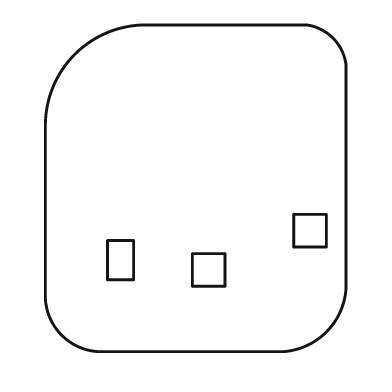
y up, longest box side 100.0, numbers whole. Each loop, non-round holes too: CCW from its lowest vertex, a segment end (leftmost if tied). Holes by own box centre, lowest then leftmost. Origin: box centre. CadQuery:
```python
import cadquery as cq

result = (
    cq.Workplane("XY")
    .moveTo(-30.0, -50.0)
    .lineTo(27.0, -50.0)
    .threePointArc((40.0, -44.0), (46.0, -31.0))
    .lineTo(46.0, 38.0)
    .threePointArc((42.0, 46.0), (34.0, 50.0))
    .lineTo(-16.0, 50.0)
    .threePointArc((-37.0, 41.0), (-46.0, 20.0))
    .lineTo(-46.0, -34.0)
    .threePointArc((-41.0, -45.0), (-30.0, -50.0))
    .close()
    .moveTo(-1.0, -30.0)
    .lineTo(9.0, -30.0)
    .lineTo(9.0, -20.0)
    .lineTo(-1.0, -20.0)
    .close()
    .moveTo(-27.0, -28.0)
    .lineTo(-19.0, -28.0)
    .lineTo(-19.0, -16.0)
    .lineTo(-27.0, -16.0)
    .close()
    .moveTo(30.0, -18.0)
    .lineTo(40.0, -18.0)
    .lineTo(40.0, -8.0)
    .lineTo(30.0, -8.0)
    .close()
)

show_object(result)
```